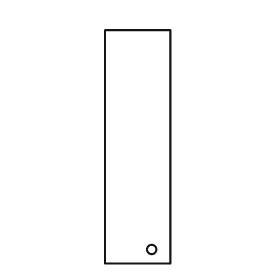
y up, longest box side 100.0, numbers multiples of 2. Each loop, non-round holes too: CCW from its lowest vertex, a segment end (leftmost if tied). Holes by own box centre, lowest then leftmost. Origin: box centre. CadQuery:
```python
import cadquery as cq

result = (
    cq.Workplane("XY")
    .moveTo(-14.0, -50.0)
    .lineTo(14.0, -50.0)
    .lineTo(14.0, 50.0)
    .lineTo(-14.0, 50.0)
    .close()
    .moveTo(6.0, -44.0)
    .circle(2.0)
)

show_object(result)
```